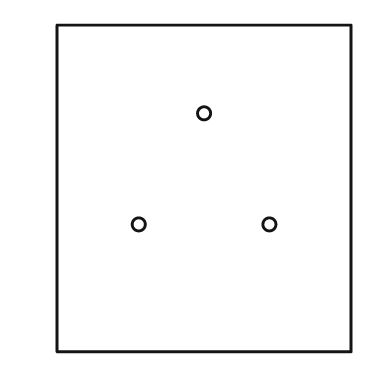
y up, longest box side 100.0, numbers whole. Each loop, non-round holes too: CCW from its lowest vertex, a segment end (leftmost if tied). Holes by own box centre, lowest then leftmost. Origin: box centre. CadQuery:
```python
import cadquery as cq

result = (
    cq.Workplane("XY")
    .moveTo(-45.0, -50.0)
    .lineTo(45.0, -50.0)
    .lineTo(45.0, 50.0)
    .lineTo(-45.0, 50.0)
    .close()
    .moveTo(-20.0, -11.0)
    .circle(2.0)
    .moveTo(20.0, -11.0)
    .circle(2.0)
    .moveTo(0.0, 23.0)
    .circle(2.0)
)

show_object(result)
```